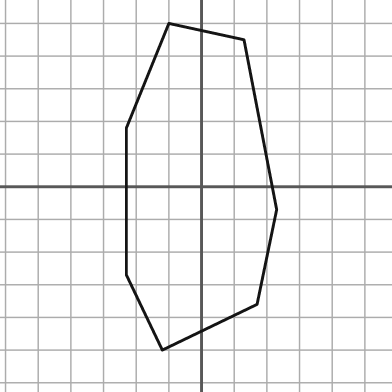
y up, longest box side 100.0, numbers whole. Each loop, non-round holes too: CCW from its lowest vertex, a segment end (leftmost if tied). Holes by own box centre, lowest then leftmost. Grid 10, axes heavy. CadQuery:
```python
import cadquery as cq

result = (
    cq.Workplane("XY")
    .moveTo(-12.0, -50.0)
    .lineTo(17.0, -36.0)
    .lineTo(23.0, -7.0)
    .lineTo(13.0, 45.0)
    .lineTo(-10.0, 50.0)
    .lineTo(-23.0, 18.0)
    .lineTo(-23.0, -27.0)
    .close()
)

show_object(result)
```